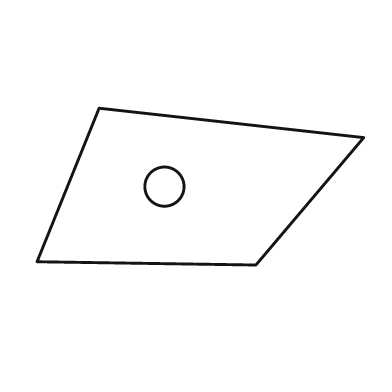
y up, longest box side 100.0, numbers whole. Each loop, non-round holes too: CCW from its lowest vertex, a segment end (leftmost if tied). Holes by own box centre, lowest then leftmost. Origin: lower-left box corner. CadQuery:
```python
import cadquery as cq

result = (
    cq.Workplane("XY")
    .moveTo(67.0, 0.0)
    .lineTo(100.0, 39.0)
    .lineTo(19.0, 48.0)
    .lineTo(0.0, 1.0)
    .close()
    .moveTo(39.0, 24.0)
    .circle(6.0)
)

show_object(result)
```